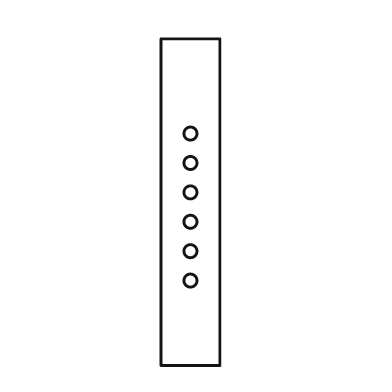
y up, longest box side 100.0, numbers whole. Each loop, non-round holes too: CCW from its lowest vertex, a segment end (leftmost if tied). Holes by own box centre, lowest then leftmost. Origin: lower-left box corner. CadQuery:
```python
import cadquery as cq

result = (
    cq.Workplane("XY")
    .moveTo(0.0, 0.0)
    .lineTo(18.0, 0.0)
    .lineTo(18.0, 100.0)
    .lineTo(0.0, 100.0)
    .close()
    .moveTo(9.0, 26.0)
    .circle(2.0)
    .moveTo(9.0, 35.0)
    .circle(2.0)
    .moveTo(9.0, 44.0)
    .circle(2.0)
    .moveTo(9.0, 53.0)
    .circle(2.0)
    .moveTo(9.0, 62.0)
    .circle(2.0)
    .moveTo(9.0, 71.0)
    .circle(2.0)
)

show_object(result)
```